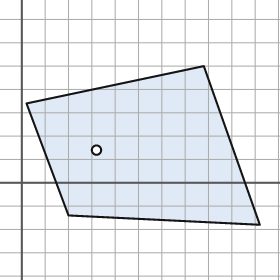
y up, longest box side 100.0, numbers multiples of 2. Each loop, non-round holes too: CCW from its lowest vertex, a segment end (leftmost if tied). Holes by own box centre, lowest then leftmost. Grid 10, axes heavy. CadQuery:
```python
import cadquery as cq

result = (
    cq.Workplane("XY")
    .moveTo(102.0, -18.0)
    .lineTo(78.0, 50.0)
    .lineTo(2.0, 34.0)
    .lineTo(20.0, -14.0)
    .close()
    .moveTo(32.0, 14.0)
    .circle(2.0)
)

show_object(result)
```